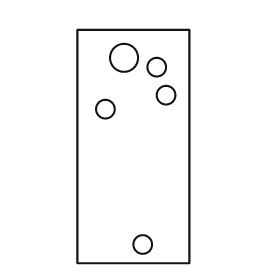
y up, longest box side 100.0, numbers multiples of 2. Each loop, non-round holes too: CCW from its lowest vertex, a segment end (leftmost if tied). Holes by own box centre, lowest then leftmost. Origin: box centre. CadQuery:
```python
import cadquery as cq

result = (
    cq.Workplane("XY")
    .moveTo(-24.0, -50.0)
    .lineTo(24.0, -50.0)
    .lineTo(24.0, 50.0)
    .lineTo(-24.0, 50.0)
    .close()
    .moveTo(4.0, -42.0)
    .circle(4.0)
    .moveTo(-12.0, 16.0)
    .circle(4.0)
    .moveTo(14.0, 22.0)
    .circle(4.0)
    .moveTo(10.0, 34.0)
    .circle(4.0)
    .moveTo(-4.0, 38.0)
    .circle(6.0)
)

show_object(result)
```